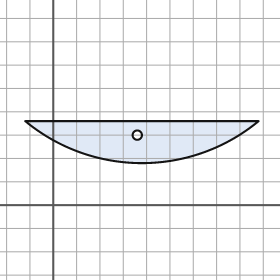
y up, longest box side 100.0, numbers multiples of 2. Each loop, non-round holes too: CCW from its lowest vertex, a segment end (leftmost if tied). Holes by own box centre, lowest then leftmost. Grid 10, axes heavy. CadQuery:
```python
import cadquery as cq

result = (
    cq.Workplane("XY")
    .moveTo(-12.0, 36.0)
    .threePointArc((38.0, 18.0), (88.0, 36.0))
    .close()
    .moveTo(36.0, 30.0)
    .circle(2.0)
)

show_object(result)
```